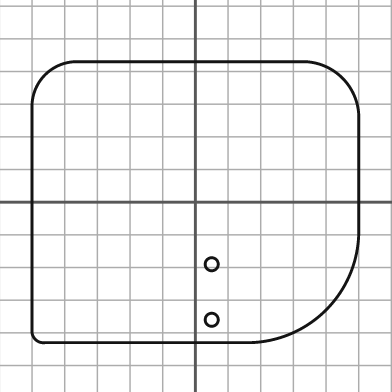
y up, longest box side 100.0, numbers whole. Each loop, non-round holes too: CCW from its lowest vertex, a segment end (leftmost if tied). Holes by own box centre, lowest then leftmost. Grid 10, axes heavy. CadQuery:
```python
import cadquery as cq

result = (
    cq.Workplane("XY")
    .moveTo(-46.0, -43.0)
    .lineTo(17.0, -43.0)
    .threePointArc((40.0, -33.0), (50.0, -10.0))
    .lineTo(50.0, 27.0)
    .threePointArc((45.0, 38.0), (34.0, 43.0))
    .lineTo(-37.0, 43.0)
    .threePointArc((-46.0, 39.0), (-50.0, 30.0))
    .lineTo(-50.0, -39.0)
    .threePointArc((-49.0, -42.0), (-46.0, -43.0))
    .close()
    .moveTo(5.0, -36.0)
    .circle(2.0)
    .moveTo(5.0, -19.0)
    .circle(2.0)
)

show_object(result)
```